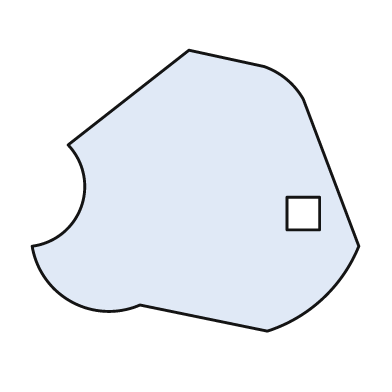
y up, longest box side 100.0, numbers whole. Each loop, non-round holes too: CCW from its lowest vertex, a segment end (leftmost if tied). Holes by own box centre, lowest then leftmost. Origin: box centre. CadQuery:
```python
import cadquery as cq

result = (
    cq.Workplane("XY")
    .moveTo(22.0, -43.0)
    .threePointArc((39.0, -33.0), (50.0, -17.0))
    .lineTo(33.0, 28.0)
    .threePointArc((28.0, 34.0), (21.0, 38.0))
    .lineTo(-2.0, 43.0)
    .lineTo(-39.0, 14.0)
    .threePointArc((-35.0, -5.0), (-50.0, -17.0))
    .threePointArc((-38.0, -34.0), (-17.0, -35.0))
    .close()
    .moveTo(28.0, -12.0)
    .lineTo(38.0, -12.0)
    .lineTo(38.0, -2.0)
    .lineTo(28.0, -2.0)
    .close()
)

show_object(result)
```